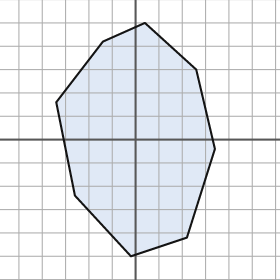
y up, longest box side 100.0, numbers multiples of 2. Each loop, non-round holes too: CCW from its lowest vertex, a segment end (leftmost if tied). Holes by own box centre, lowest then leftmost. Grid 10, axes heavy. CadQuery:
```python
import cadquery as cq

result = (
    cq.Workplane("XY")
    .moveTo(-2.0, -50.0)
    .lineTo(22.0, -42.0)
    .lineTo(34.0, -4.0)
    .lineTo(26.0, 30.0)
    .lineTo(4.0, 50.0)
    .lineTo(-14.0, 42.0)
    .lineTo(-34.0, 16.0)
    .lineTo(-26.0, -24.0)
    .close()
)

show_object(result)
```